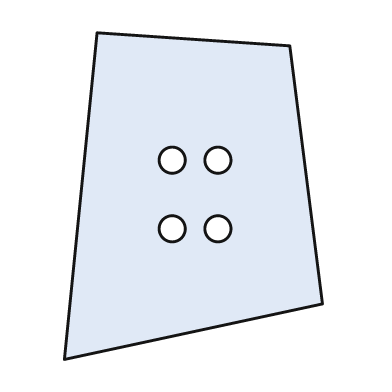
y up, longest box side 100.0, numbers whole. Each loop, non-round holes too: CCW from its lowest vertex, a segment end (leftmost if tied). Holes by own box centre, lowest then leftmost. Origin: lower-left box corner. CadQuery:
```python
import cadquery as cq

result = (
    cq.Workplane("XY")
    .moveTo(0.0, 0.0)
    .lineTo(79.0, 17.0)
    .lineTo(69.0, 96.0)
    .lineTo(10.0, 100.0)
    .close()
    .moveTo(33.0, 40.0)
    .circle(4.0)
    .moveTo(47.0, 40.0)
    .circle(4.0)
    .moveTo(33.0, 61.0)
    .circle(4.0)
    .moveTo(47.0, 61.0)
    .circle(4.0)
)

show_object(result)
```